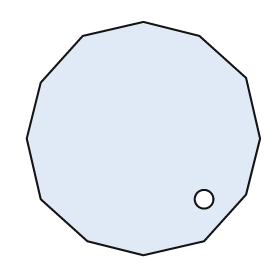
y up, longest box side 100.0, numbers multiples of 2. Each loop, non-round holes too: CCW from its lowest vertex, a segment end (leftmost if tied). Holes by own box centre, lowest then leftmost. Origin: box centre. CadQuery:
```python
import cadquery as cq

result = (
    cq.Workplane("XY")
    .moveTo(0.0, -50.0)
    .lineTo(26.0, -44.0)
    .lineTo(44.0, -24.0)
    .lineTo(50.0, 0.0)
    .lineTo(44.0, 26.0)
    .lineTo(24.0, 44.0)
    .lineTo(0.0, 50.0)
    .lineTo(-26.0, 44.0)
    .lineTo(-44.0, 24.0)
    .lineTo(-50.0, 0.0)
    .lineTo(-44.0, -26.0)
    .lineTo(-24.0, -44.0)
    .close()
    .moveTo(26.0, -26.0)
    .circle(4.0)
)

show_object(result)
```